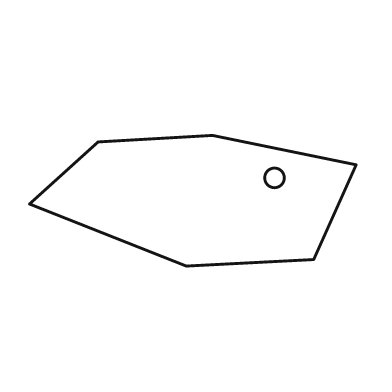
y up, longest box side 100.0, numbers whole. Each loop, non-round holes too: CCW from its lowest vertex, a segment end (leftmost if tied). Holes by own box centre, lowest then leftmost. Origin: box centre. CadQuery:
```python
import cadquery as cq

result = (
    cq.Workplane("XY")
    .moveTo(-2.0, -20.0)
    .lineTo(37.0, -18.0)
    .lineTo(50.0, 11.0)
    .lineTo(6.0, 20.0)
    .lineTo(-29.0, 18.0)
    .lineTo(-50.0, -1.0)
    .close()
    .moveTo(25.0, 7.0)
    .circle(3.0)
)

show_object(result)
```